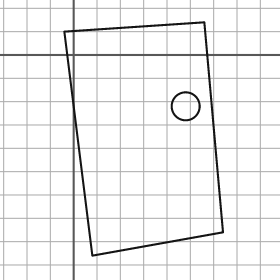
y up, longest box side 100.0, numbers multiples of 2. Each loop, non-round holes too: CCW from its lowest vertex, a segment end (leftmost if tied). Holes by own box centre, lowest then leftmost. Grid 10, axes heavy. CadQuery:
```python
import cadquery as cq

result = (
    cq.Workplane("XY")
    .moveTo(8.0, -86.0)
    .lineTo(64.0, -76.0)
    .lineTo(56.0, 14.0)
    .lineTo(-4.0, 10.0)
    .close()
    .moveTo(48.0, -22.0)
    .circle(6.0)
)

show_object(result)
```